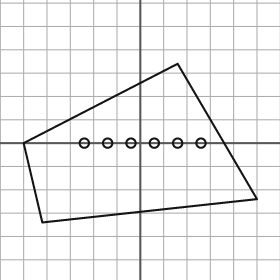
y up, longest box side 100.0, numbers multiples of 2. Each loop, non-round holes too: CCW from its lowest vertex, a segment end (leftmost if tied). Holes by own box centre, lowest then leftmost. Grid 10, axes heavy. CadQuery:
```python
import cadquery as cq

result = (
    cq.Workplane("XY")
    .moveTo(-42.0, -34.0)
    .lineTo(50.0, -24.0)
    .lineTo(16.0, 34.0)
    .lineTo(-50.0, 0.0)
    .close()
    .moveTo(-24.0, 0.0)
    .circle(2.0)
    .moveTo(-14.0, 0.0)
    .circle(2.0)
    .moveTo(-4.0, 0.0)
    .circle(2.0)
    .moveTo(6.0, 0.0)
    .circle(2.0)
    .moveTo(16.0, 0.0)
    .circle(2.0)
    .moveTo(26.0, 0.0)
    .circle(2.0)
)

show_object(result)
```